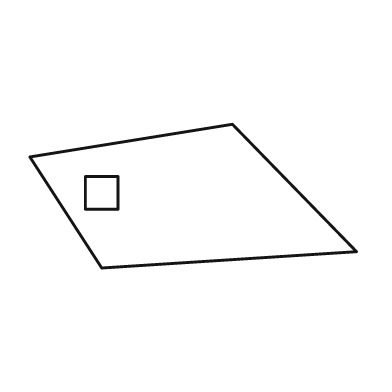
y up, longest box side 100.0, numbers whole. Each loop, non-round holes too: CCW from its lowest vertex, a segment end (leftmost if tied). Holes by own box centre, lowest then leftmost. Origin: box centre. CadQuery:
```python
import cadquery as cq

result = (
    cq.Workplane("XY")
    .moveTo(-28.0, -22.0)
    .lineTo(50.0, -17.0)
    .lineTo(12.0, 22.0)
    .lineTo(-50.0, 12.0)
    .close()
    .moveTo(-33.0, -4.0)
    .lineTo(-23.0, -4.0)
    .lineTo(-23.0, 6.0)
    .lineTo(-33.0, 6.0)
    .close()
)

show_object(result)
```